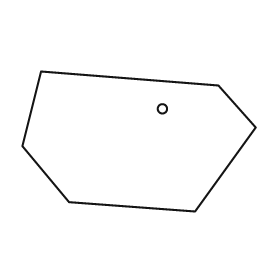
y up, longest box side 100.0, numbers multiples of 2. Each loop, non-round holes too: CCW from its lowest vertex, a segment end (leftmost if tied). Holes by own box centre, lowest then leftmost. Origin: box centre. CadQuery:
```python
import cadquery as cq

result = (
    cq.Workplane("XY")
    .moveTo(24.0, -30.0)
    .lineTo(50.0, 6.0)
    .lineTo(34.0, 24.0)
    .lineTo(-42.0, 30.0)
    .lineTo(-50.0, -2.0)
    .lineTo(-30.0, -26.0)
    .close()
    .moveTo(10.0, 14.0)
    .circle(2.0)
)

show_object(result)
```